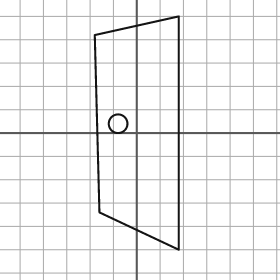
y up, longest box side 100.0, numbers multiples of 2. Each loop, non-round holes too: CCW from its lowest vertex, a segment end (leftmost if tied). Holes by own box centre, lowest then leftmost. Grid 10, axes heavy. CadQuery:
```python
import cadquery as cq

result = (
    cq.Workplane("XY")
    .moveTo(18.0, -50.0)
    .lineTo(18.0, 50.0)
    .lineTo(-18.0, 42.0)
    .lineTo(-16.0, -34.0)
    .close()
    .moveTo(-8.0, 4.0)
    .circle(4.0)
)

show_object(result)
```